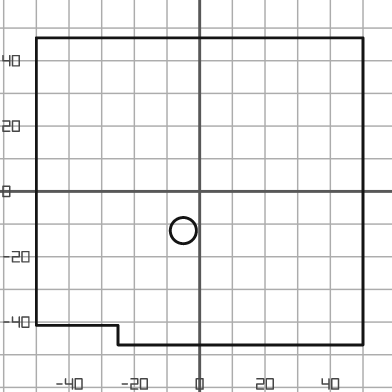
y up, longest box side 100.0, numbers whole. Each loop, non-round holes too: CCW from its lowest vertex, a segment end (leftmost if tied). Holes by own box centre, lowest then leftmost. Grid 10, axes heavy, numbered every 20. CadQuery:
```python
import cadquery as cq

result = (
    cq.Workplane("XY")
    .moveTo(-25.0, -47.0)
    .lineTo(50.0, -47.0)
    .lineTo(50.0, 47.0)
    .lineTo(-50.0, 47.0)
    .lineTo(-50.0, -41.0)
    .lineTo(-25.0, -41.0)
    .close()
    .moveTo(-5.0, -12.0)
    .circle(4.0)
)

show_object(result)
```